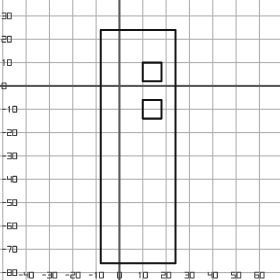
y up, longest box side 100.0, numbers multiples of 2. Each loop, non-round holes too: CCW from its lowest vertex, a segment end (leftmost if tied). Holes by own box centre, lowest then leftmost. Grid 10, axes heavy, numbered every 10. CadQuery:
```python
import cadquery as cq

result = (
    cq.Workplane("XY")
    .moveTo(-8.0, -76.0)
    .lineTo(24.0, -76.0)
    .lineTo(24.0, 24.0)
    .lineTo(-8.0, 24.0)
    .close()
    .moveTo(10.0, -14.0)
    .lineTo(18.0, -14.0)
    .lineTo(18.0, -6.0)
    .lineTo(10.0, -6.0)
    .close()
    .moveTo(10.0, 2.0)
    .lineTo(18.0, 2.0)
    .lineTo(18.0, 10.0)
    .lineTo(10.0, 10.0)
    .close()
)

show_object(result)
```